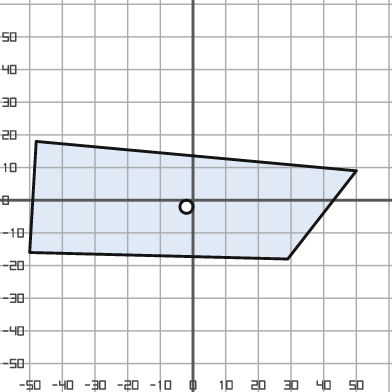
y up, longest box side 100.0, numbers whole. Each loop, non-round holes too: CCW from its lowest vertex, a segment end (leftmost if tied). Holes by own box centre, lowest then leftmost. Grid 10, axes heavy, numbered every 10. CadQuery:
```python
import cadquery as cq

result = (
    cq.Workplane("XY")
    .moveTo(29.0, -18.0)
    .lineTo(50.0, 9.0)
    .lineTo(-48.0, 18.0)
    .lineTo(-50.0, -16.0)
    .close()
    .moveTo(-2.0, -2.0)
    .circle(2.0)
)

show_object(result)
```